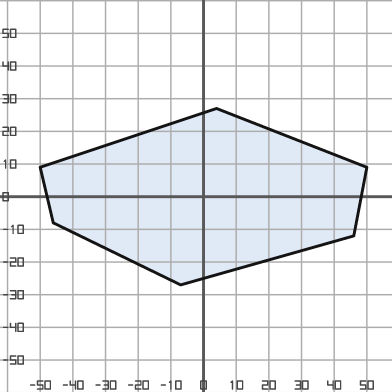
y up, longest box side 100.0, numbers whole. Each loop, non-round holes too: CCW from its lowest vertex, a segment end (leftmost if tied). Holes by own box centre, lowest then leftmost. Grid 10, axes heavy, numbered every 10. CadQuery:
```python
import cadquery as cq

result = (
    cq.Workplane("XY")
    .moveTo(-7.0, -27.0)
    .lineTo(46.0, -12.0)
    .lineTo(50.0, 9.0)
    .lineTo(4.0, 27.0)
    .lineTo(-50.0, 9.0)
    .lineTo(-46.0, -8.0)
    .close()
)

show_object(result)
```